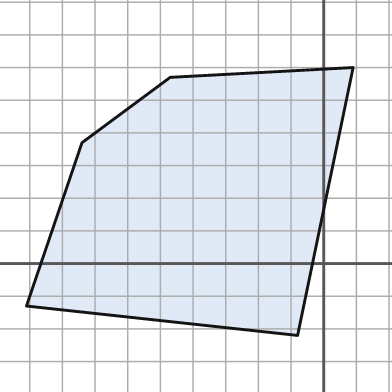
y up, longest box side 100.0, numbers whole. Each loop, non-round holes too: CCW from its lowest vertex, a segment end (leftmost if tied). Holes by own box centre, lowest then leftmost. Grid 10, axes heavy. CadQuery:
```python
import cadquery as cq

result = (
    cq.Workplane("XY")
    .moveTo(-8.0, -22.0)
    .lineTo(9.0, 60.0)
    .lineTo(-47.0, 57.0)
    .lineTo(-74.0, 37.0)
    .lineTo(-91.0, -13.0)
    .close()
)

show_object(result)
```